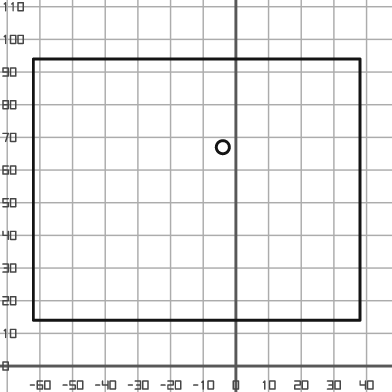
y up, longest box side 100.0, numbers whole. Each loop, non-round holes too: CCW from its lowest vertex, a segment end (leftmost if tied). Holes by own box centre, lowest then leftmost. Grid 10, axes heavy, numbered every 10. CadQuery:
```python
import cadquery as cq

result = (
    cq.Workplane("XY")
    .moveTo(-62.0, 14.0)
    .lineTo(38.0, 14.0)
    .lineTo(38.0, 94.0)
    .lineTo(-62.0, 94.0)
    .close()
    .moveTo(-4.0, 67.0)
    .circle(2.0)
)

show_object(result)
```